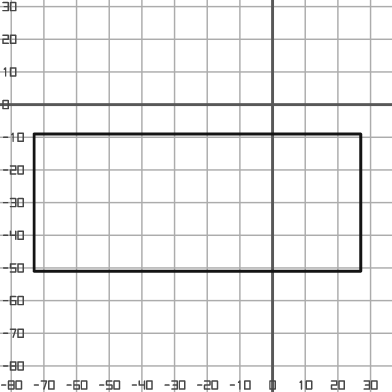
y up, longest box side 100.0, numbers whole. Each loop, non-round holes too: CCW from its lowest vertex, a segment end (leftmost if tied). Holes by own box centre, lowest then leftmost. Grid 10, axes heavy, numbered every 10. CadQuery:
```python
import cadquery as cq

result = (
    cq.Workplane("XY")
    .moveTo(-73.0, -51.0)
    .lineTo(27.0, -51.0)
    .lineTo(27.0, -9.0)
    .lineTo(-73.0, -9.0)
    .close()
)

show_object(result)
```